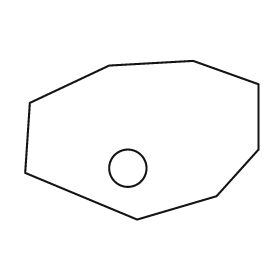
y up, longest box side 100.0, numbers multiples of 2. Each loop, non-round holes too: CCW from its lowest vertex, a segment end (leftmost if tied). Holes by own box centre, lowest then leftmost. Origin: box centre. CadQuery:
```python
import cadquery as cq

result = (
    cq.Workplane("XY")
    .moveTo(-2.0, -34.0)
    .lineTo(32.0, -24.0)
    .lineTo(50.0, -4.0)
    .lineTo(50.0, 24.0)
    .lineTo(22.0, 34.0)
    .lineTo(-14.0, 32.0)
    .lineTo(-48.0, 16.0)
    .lineTo(-50.0, -14.0)
    .close()
    .moveTo(-6.0, -12.0)
    .circle(8.0)
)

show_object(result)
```